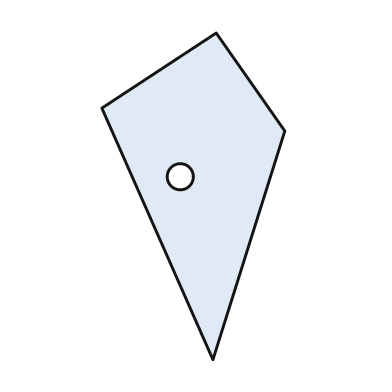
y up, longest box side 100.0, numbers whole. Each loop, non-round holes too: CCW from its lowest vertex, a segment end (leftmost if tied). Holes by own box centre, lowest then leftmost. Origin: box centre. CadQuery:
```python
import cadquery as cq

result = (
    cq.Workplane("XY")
    .moveTo(6.0, -50.0)
    .lineTo(28.0, 20.0)
    .lineTo(7.0, 50.0)
    .lineTo(-28.0, 27.0)
    .close()
    .moveTo(-4.0, 6.0)
    .circle(4.0)
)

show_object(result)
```